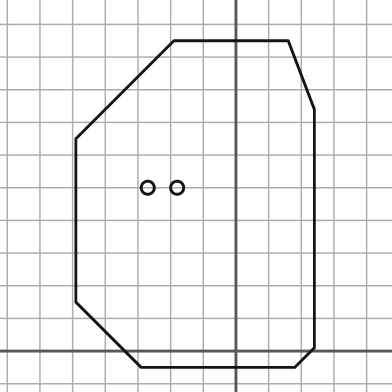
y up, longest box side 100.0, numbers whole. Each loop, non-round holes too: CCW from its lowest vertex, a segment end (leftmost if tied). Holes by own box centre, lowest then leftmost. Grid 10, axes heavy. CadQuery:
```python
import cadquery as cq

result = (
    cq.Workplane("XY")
    .moveTo(-29.0, -5.0)
    .lineTo(18.0, -5.0)
    .lineTo(24.0, 1.0)
    .lineTo(24.0, 74.0)
    .lineTo(16.0, 95.0)
    .lineTo(-19.0, 95.0)
    .lineTo(-49.0, 65.0)
    .lineTo(-49.0, 15.0)
    .close()
    .moveTo(-27.0, 50.0)
    .circle(2.0)
    .moveTo(-18.0, 50.0)
    .circle(2.0)
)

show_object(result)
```